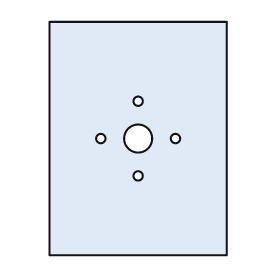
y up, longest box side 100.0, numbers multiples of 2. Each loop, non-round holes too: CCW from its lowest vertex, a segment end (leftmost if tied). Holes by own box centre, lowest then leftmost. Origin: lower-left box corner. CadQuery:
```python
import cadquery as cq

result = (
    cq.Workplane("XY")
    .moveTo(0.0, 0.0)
    .lineTo(76.0, 0.0)
    .lineTo(76.0, 100.0)
    .lineTo(0.0, 100.0)
    .close()
    .moveTo(38.0, 34.0)
    .circle(2.0)
    .moveTo(22.0, 50.0)
    .circle(2.0)
    .moveTo(38.0, 50.0)
    .circle(6.0)
    .moveTo(54.0, 50.0)
    .circle(2.0)
    .moveTo(38.0, 66.0)
    .circle(2.0)
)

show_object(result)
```